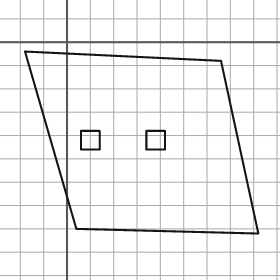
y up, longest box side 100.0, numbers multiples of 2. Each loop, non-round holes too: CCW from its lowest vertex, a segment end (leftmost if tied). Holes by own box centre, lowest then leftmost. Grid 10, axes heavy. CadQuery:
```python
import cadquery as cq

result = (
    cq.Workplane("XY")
    .moveTo(82.0, -82.0)
    .lineTo(66.0, -8.0)
    .lineTo(-18.0, -4.0)
    .lineTo(4.0, -80.0)
    .close()
    .moveTo(6.0, -46.0)
    .lineTo(14.0, -46.0)
    .lineTo(14.0, -38.0)
    .lineTo(6.0, -38.0)
    .close()
    .moveTo(34.0, -46.0)
    .lineTo(42.0, -46.0)
    .lineTo(42.0, -38.0)
    .lineTo(34.0, -38.0)
    .close()
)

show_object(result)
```